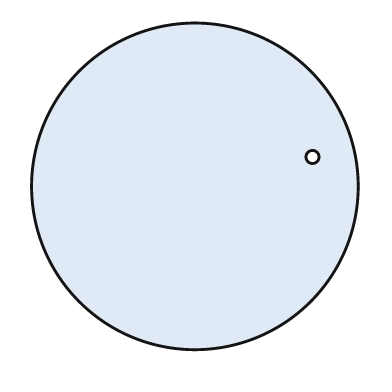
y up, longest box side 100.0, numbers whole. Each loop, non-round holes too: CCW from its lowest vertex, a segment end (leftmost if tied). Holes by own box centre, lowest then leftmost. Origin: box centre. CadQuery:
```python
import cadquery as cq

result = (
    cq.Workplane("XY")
    .moveTo(0.0, 0.0)
    .circle(50.0)
    .moveTo(36.0, 9.0)
    .circle(2.0)
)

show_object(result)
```